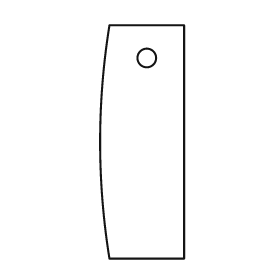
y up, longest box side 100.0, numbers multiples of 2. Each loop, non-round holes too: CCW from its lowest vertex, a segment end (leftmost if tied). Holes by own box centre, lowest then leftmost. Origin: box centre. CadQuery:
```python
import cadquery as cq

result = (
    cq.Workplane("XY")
    .moveTo(-14.0, -50.0)
    .lineTo(18.0, -50.0)
    .lineTo(18.0, 50.0)
    .lineTo(-14.0, 50.0)
    .threePointArc((-18.0, 0.0), (-14.0, -50.0))
    .close()
    .moveTo(2.0, 36.0)
    .circle(4.0)
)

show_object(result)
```